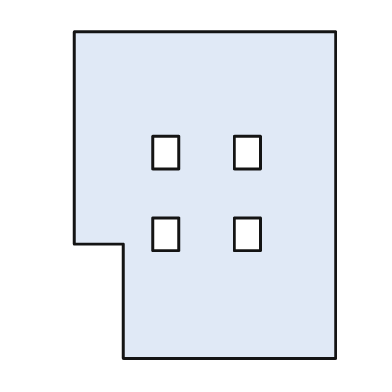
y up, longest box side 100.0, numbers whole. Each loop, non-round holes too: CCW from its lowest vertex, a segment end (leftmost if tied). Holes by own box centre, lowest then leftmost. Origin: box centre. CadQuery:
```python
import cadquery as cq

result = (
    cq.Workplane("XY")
    .moveTo(-25.0, -50.0)
    .lineTo(40.0, -50.0)
    .lineTo(40.0, 50.0)
    .lineTo(-40.0, 50.0)
    .lineTo(-40.0, -15.0)
    .lineTo(-25.0, -15.0)
    .close()
    .moveTo(-16.0, -17.0)
    .lineTo(-8.0, -17.0)
    .lineTo(-8.0, -7.0)
    .lineTo(-16.0, -7.0)
    .close()
    .moveTo(9.0, -17.0)
    .lineTo(17.0, -17.0)
    .lineTo(17.0, -7.0)
    .lineTo(9.0, -7.0)
    .close()
    .moveTo(-16.0, 8.0)
    .lineTo(-8.0, 8.0)
    .lineTo(-8.0, 18.0)
    .lineTo(-16.0, 18.0)
    .close()
    .moveTo(9.0, 8.0)
    .lineTo(17.0, 8.0)
    .lineTo(17.0, 18.0)
    .lineTo(9.0, 18.0)
    .close()
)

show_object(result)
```